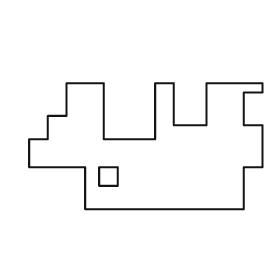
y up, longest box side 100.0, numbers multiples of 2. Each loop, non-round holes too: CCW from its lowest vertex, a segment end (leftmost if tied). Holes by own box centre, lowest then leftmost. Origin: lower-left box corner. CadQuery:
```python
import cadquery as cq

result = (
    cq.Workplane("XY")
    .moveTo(24.0, 0.0)
    .lineTo(92.0, 0.0)
    .lineTo(92.0, 18.0)
    .lineTo(100.0, 18.0)
    .lineTo(100.0, 36.0)
    .lineTo(92.0, 36.0)
    .lineTo(92.0, 50.0)
    .lineTo(100.0, 50.0)
    .lineTo(100.0, 54.0)
    .lineTo(76.0, 54.0)
    .lineTo(76.0, 36.0)
    .lineTo(62.0, 36.0)
    .lineTo(62.0, 54.0)
    .lineTo(54.0, 54.0)
    .lineTo(54.0, 30.0)
    .lineTo(32.0, 30.0)
    .lineTo(32.0, 54.0)
    .lineTo(16.0, 54.0)
    .lineTo(16.0, 40.0)
    .lineTo(8.0, 40.0)
    .lineTo(8.0, 30.0)
    .lineTo(0.0, 30.0)
    .lineTo(0.0, 18.0)
    .lineTo(24.0, 18.0)
    .close()
    .moveTo(30.0, 10.0)
    .lineTo(38.0, 10.0)
    .lineTo(38.0, 18.0)
    .lineTo(30.0, 18.0)
    .close()
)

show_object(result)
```